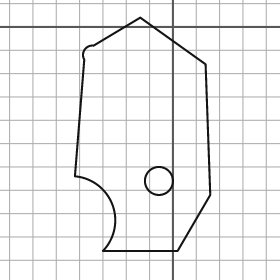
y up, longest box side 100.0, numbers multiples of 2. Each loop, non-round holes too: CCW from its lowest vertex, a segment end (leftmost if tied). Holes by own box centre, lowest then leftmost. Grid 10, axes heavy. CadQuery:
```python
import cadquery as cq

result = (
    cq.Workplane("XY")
    .moveTo(-30.0, -96.0)
    .lineTo(2.0, -96.0)
    .lineTo(16.0, -72.0)
    .lineTo(14.0, -16.0)
    .lineTo(-14.0, 4.0)
    .lineTo(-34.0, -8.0)
    .threePointArc((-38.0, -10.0), (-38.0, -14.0))
    .lineTo(-42.0, -64.0)
    .threePointArc((-26.0, -76.0), (-30.0, -96.0))
    .close()
    .moveTo(-6.0, -66.0)
    .circle(6.0)
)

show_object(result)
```